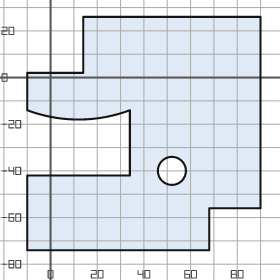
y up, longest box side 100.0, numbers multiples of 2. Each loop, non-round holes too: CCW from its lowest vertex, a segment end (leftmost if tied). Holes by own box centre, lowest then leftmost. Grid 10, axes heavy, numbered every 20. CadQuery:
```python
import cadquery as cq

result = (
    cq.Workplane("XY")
    .moveTo(-10.0, -74.0)
    .lineTo(68.0, -74.0)
    .lineTo(68.0, -56.0)
    .lineTo(90.0, -56.0)
    .lineTo(90.0, 26.0)
    .lineTo(14.0, 26.0)
    .lineTo(14.0, 2.0)
    .lineTo(-10.0, 2.0)
    .lineTo(-10.0, -14.0)
    .threePointArc((12.0, -18.0), (34.0, -14.0))
    .lineTo(34.0, -42.0)
    .lineTo(-10.0, -42.0)
    .close()
    .moveTo(52.0, -40.0)
    .circle(6.0)
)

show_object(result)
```